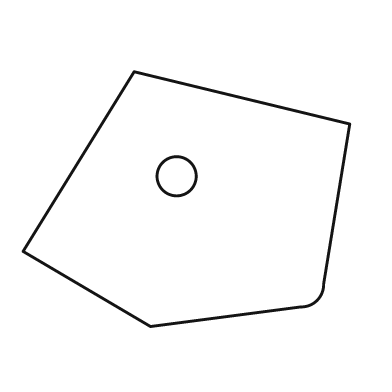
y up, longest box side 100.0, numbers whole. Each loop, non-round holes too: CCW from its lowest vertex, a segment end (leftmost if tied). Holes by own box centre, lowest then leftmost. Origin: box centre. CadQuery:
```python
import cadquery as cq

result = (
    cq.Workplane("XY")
    .moveTo(-11.0, -39.0)
    .lineTo(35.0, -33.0)
    .threePointArc((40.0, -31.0), (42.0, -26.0))
    .lineTo(50.0, 23.0)
    .lineTo(-16.0, 39.0)
    .lineTo(-50.0, -16.0)
    .close()
    .moveTo(-3.0, 7.0)
    .circle(6.0)
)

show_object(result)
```